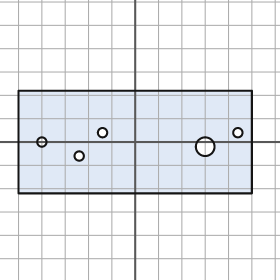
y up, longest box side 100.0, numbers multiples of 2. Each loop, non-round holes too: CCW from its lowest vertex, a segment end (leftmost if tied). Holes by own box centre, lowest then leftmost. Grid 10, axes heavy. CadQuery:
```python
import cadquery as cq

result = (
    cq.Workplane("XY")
    .moveTo(-50.0, -22.0)
    .lineTo(50.0, -22.0)
    .lineTo(50.0, 22.0)
    .lineTo(-50.0, 22.0)
    .close()
    .moveTo(-24.0, -6.0)
    .circle(2.0)
    .moveTo(30.0, -2.0)
    .circle(4.0)
    .moveTo(-40.0, 0.0)
    .circle(2.0)
    .moveTo(-14.0, 4.0)
    .circle(2.0)
    .moveTo(44.0, 4.0)
    .circle(2.0)
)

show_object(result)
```